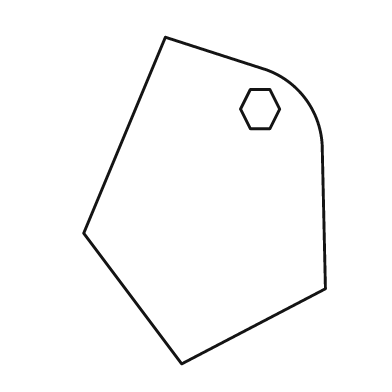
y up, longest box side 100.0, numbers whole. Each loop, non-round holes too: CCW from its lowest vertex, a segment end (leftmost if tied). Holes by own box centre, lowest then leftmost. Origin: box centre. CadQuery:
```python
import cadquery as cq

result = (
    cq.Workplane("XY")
    .moveTo(-7.0, -50.0)
    .lineTo(37.0, -27.0)
    .lineTo(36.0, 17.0)
    .threePointArc((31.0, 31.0), (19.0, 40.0))
    .lineTo(-12.0, 50.0)
    .lineTo(-37.0, -10.0)
    .close()
    .moveTo(14.0, 22.0)
    .lineTo(20.0, 22.0)
    .lineTo(23.0, 28.0)
    .lineTo(20.0, 34.0)
    .lineTo(14.0, 34.0)
    .lineTo(11.0, 28.0)
    .close()
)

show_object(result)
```